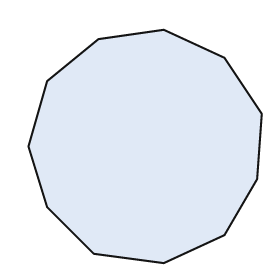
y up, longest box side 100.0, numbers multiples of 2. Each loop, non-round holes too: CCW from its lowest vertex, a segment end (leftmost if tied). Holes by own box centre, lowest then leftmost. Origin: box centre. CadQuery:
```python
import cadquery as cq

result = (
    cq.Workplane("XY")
    .moveTo(8.0, -50.0)
    .lineTo(34.0, -38.0)
    .lineTo(48.0, -14.0)
    .lineTo(50.0, 14.0)
    .lineTo(34.0, 38.0)
    .lineTo(8.0, 50.0)
    .lineTo(-20.0, 46.0)
    .lineTo(-42.0, 28.0)
    .lineTo(-50.0, 0.0)
    .lineTo(-42.0, -26.0)
    .lineTo(-22.0, -46.0)
    .close()
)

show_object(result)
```